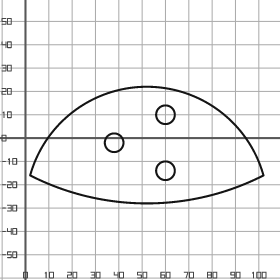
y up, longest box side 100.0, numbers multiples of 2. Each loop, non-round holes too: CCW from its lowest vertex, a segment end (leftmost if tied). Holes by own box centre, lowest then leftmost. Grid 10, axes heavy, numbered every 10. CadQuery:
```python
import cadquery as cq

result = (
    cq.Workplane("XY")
    .moveTo(2.0, -16.0)
    .threePointArc((52.0, -28.0), (102.0, -16.0))
    .threePointArc((52.0, 22.0), (2.0, -16.0))
    .close()
    .moveTo(60.0, -14.0)
    .circle(4.0)
    .moveTo(38.0, -2.0)
    .circle(4.0)
    .moveTo(60.0, 10.0)
    .circle(4.0)
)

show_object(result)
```